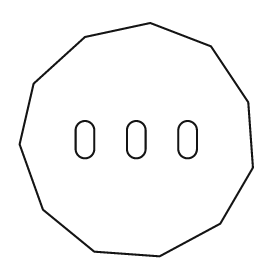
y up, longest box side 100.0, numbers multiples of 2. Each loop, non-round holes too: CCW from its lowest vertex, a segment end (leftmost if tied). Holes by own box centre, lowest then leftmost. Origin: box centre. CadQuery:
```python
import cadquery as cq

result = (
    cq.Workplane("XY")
    .moveTo(10.0, -50.0)
    .lineTo(36.0, -36.0)
    .lineTo(50.0, -12.0)
    .lineTo(48.0, 16.0)
    .lineTo(32.0, 40.0)
    .lineTo(6.0, 50.0)
    .lineTo(-22.0, 44.0)
    .lineTo(-44.0, 24.0)
    .lineTo(-50.0, -2.0)
    .lineTo(-40.0, -30.0)
    .lineTo(-18.0, -48.0)
    .close()
    .moveTo(-26.0, -4.0)
    .threePointArc((-22.0, -8.0), (-18.0, -4.0))
    .lineTo(-18.0, 4.0)
    .threePointArc((-22.0, 8.0), (-26.0, 4.0))
    .close()
    .moveTo(-4.0, -4.0)
    .threePointArc((0.0, -8.0), (4.0, -4.0))
    .lineTo(4.0, 4.0)
    .threePointArc((0.0, 8.0), (-4.0, 4.0))
    .close()
    .moveTo(18.0, -4.0)
    .threePointArc((22.0, -8.0), (26.0, -4.0))
    .lineTo(26.0, 4.0)
    .threePointArc((22.0, 8.0), (18.0, 4.0))
    .close()
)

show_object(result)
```